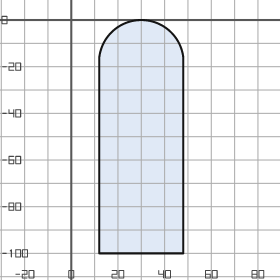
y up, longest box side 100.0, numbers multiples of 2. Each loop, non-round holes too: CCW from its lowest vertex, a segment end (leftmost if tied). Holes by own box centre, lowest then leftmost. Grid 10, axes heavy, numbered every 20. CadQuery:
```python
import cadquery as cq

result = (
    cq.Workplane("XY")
    .moveTo(12.0, -100.0)
    .lineTo(48.0, -100.0)
    .lineTo(48.0, -16.0)
    .threePointArc((30.0, 0.0), (12.0, -16.0))
    .close()
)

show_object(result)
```